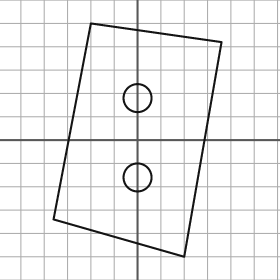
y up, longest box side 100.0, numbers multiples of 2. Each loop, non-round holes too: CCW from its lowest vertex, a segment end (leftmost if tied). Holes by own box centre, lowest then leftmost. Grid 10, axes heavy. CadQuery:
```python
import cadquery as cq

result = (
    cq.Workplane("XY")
    .moveTo(20.0, -50.0)
    .lineTo(36.0, 42.0)
    .lineTo(-20.0, 50.0)
    .lineTo(-36.0, -34.0)
    .close()
    .moveTo(0.0, -16.0)
    .circle(6.0)
    .moveTo(0.0, 18.0)
    .circle(6.0)
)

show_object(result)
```